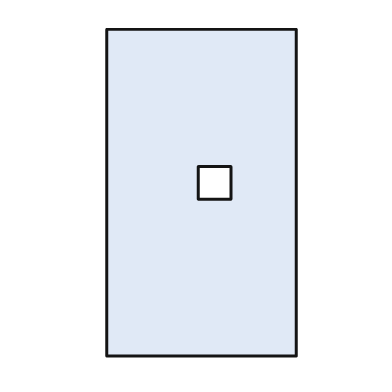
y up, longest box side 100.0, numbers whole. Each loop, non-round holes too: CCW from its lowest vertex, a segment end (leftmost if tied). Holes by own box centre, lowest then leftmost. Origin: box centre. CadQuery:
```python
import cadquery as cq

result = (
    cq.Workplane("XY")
    .moveTo(-29.0, -50.0)
    .lineTo(29.0, -50.0)
    .lineTo(29.0, 50.0)
    .lineTo(-29.0, 50.0)
    .close()
    .moveTo(-1.0, -2.0)
    .lineTo(9.0, -2.0)
    .lineTo(9.0, 8.0)
    .lineTo(-1.0, 8.0)
    .close()
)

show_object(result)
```